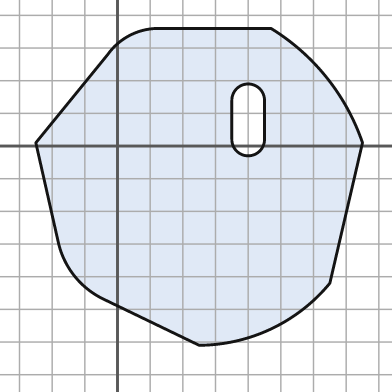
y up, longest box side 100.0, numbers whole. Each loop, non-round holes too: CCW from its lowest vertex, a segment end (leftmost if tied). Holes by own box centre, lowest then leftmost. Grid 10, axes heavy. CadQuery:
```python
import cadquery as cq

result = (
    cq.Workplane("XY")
    .moveTo(25.0, -61.0)
    .threePointArc((47.0, -56.0), (65.0, -42.0))
    .lineTo(75.0, 1.0)
    .threePointArc((64.0, 21.0), (47.0, 36.0))
    .lineTo(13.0, 36.0)
    .threePointArc((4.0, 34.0), (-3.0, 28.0))
    .lineTo(-25.0, 1.0)
    .lineTo(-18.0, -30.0)
    .threePointArc((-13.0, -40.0), (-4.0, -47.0))
    .close()
    .moveTo(35.0, 2.0)
    .threePointArc((40.0, -3.0), (45.0, 2.0))
    .lineTo(45.0, 14.0)
    .threePointArc((40.0, 19.0), (35.0, 14.0))
    .close()
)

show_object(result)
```